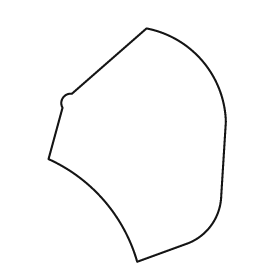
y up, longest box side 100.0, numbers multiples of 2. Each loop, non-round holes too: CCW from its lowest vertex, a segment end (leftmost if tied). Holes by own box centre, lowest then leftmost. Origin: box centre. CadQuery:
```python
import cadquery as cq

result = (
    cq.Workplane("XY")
    .moveTo(0.0, -50.0)
    .lineTo(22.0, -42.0)
    .threePointArc((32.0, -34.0), (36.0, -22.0))
    .lineTo(38.0, 10.0)
    .threePointArc((28.0, 36.0), (4.0, 50.0))
    .lineTo(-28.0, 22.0)
    .threePointArc((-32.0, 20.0), (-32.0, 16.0))
    .lineTo(-38.0, -6.0)
    .threePointArc((-14.0, -24.0), (0.0, -50.0))
    .close()
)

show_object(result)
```